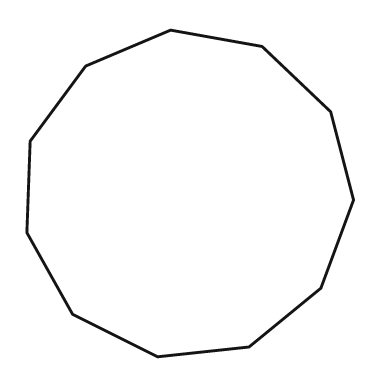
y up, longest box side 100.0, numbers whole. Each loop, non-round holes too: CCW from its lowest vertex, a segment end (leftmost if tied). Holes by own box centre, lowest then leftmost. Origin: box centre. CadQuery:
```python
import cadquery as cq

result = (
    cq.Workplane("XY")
    .moveTo(-10.0, -50.0)
    .lineTo(18.0, -47.0)
    .lineTo(40.0, -29.0)
    .lineTo(50.0, -2.0)
    .lineTo(43.0, 25.0)
    .lineTo(22.0, 45.0)
    .lineTo(-6.0, 50.0)
    .lineTo(-32.0, 39.0)
    .lineTo(-49.0, 16.0)
    .lineTo(-50.0, -12.0)
    .lineTo(-36.0, -37.0)
    .close()
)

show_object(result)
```